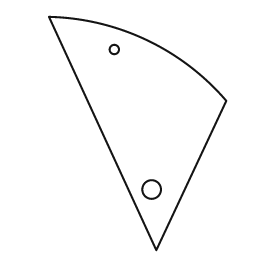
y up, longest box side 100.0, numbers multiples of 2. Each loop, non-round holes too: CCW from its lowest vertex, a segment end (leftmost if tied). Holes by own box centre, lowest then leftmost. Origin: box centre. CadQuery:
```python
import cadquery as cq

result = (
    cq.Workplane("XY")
    .moveTo(8.0, -50.0)
    .lineTo(38.0, 14.0)
    .threePointArc((4.0, 40.0), (-38.0, 50.0))
    .close()
    .moveTo(6.0, -24.0)
    .circle(4.0)
    .moveTo(-10.0, 36.0)
    .circle(2.0)
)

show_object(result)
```